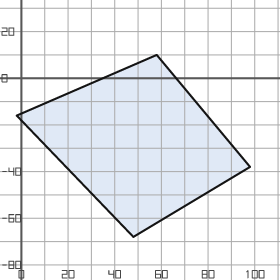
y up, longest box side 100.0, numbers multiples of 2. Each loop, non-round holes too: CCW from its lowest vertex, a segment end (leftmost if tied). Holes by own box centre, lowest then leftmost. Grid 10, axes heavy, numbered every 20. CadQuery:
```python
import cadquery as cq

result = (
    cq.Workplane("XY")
    .moveTo(48.0, -68.0)
    .lineTo(98.0, -38.0)
    .lineTo(58.0, 10.0)
    .lineTo(-2.0, -16.0)
    .close()
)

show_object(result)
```